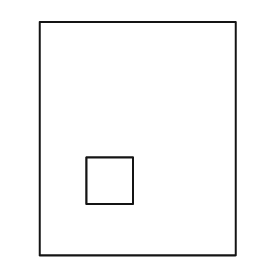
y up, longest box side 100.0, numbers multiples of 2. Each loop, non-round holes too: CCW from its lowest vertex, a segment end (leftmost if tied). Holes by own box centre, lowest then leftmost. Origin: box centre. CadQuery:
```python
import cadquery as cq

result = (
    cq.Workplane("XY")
    .moveTo(-42.0, -50.0)
    .lineTo(42.0, -50.0)
    .lineTo(42.0, 50.0)
    .lineTo(-42.0, 50.0)
    .close()
    .moveTo(-22.0, -28.0)
    .lineTo(-2.0, -28.0)
    .lineTo(-2.0, -8.0)
    .lineTo(-22.0, -8.0)
    .close()
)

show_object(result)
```